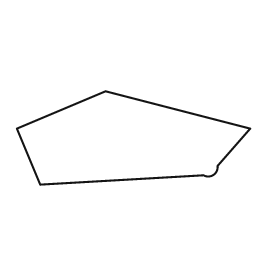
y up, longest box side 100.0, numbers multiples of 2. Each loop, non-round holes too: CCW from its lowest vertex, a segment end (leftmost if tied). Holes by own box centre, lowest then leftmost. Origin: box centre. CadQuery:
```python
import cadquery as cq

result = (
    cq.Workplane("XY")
    .moveTo(-40.0, -20.0)
    .lineTo(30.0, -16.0)
    .threePointArc((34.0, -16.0), (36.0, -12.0))
    .lineTo(50.0, 4.0)
    .lineTo(-12.0, 20.0)
    .lineTo(-50.0, 4.0)
    .close()
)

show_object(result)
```